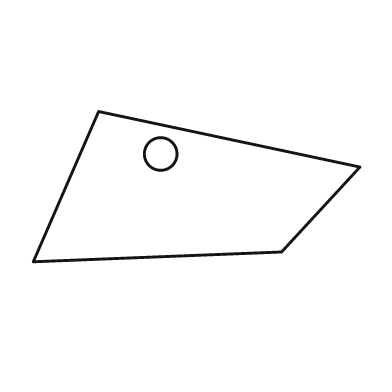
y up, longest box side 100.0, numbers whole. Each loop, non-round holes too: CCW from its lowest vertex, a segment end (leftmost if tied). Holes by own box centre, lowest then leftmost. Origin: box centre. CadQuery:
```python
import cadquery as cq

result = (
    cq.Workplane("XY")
    .moveTo(-50.0, -23.0)
    .lineTo(26.0, -20.0)
    .lineTo(50.0, 6.0)
    .lineTo(-30.0, 23.0)
    .close()
    .moveTo(-11.0, 10.0)
    .circle(5.0)
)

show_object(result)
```